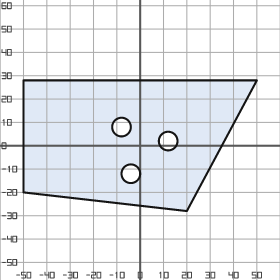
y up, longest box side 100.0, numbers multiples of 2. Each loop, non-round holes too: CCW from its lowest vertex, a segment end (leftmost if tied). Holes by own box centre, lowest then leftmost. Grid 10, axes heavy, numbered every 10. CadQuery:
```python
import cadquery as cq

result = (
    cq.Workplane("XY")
    .moveTo(20.0, -28.0)
    .lineTo(50.0, 28.0)
    .lineTo(-50.0, 28.0)
    .lineTo(-50.0, -20.0)
    .close()
    .moveTo(-4.0, -12.0)
    .circle(4.0)
    .moveTo(12.0, 2.0)
    .circle(4.0)
    .moveTo(-8.0, 8.0)
    .circle(4.0)
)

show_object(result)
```